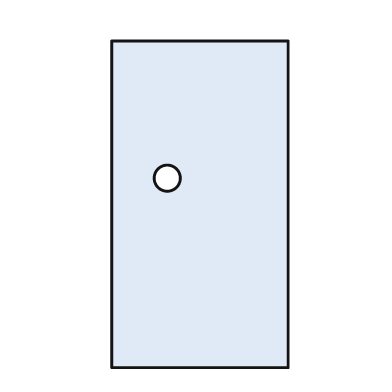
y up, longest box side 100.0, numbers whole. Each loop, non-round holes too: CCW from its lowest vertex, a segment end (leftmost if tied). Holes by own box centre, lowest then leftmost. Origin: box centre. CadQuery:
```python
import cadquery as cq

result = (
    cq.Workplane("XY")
    .moveTo(-27.0, -50.0)
    .lineTo(27.0, -50.0)
    .lineTo(27.0, 50.0)
    .lineTo(-27.0, 50.0)
    .close()
    .moveTo(-10.0, 8.0)
    .circle(4.0)
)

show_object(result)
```